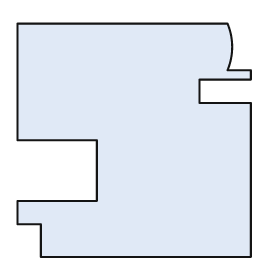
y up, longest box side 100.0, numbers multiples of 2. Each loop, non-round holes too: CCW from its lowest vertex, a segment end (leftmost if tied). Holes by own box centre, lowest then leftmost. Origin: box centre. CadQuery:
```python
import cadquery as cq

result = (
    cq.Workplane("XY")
    .moveTo(-40.0, -50.0)
    .lineTo(50.0, -50.0)
    .lineTo(50.0, 16.0)
    .lineTo(28.0, 16.0)
    .lineTo(28.0, 26.0)
    .lineTo(50.0, 26.0)
    .lineTo(50.0, 30.0)
    .lineTo(40.0, 30.0)
    .threePointArc((42.0, 40.0), (40.0, 50.0))
    .lineTo(-50.0, 50.0)
    .lineTo(-50.0, 0.0)
    .lineTo(-16.0, 0.0)
    .lineTo(-16.0, -26.0)
    .lineTo(-50.0, -26.0)
    .lineTo(-50.0, -36.0)
    .lineTo(-40.0, -36.0)
    .close()
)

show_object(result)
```